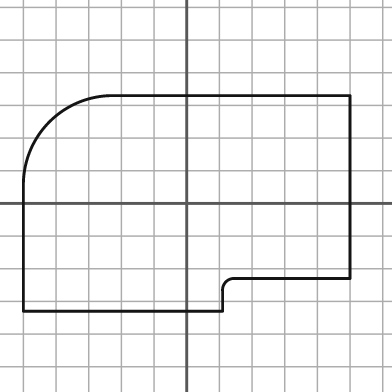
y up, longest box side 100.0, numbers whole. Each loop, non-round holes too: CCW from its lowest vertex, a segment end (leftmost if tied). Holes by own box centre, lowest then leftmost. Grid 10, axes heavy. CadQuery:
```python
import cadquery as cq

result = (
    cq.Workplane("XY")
    .moveTo(-50.0, -33.0)
    .lineTo(11.0, -33.0)
    .lineTo(11.0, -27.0)
    .threePointArc((12.0, -24.0), (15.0, -23.0))
    .lineTo(50.0, -23.0)
    .lineTo(50.0, 33.0)
    .lineTo(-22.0, 33.0)
    .threePointArc((-42.0, 25.0), (-50.0, 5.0))
    .close()
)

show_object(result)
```